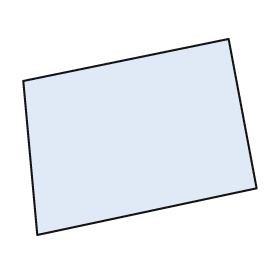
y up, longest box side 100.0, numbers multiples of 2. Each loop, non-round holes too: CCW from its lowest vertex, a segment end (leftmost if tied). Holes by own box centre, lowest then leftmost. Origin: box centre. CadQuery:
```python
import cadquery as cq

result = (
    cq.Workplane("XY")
    .moveTo(-44.0, -42.0)
    .lineTo(50.0, -22.0)
    .lineTo(38.0, 42.0)
    .lineTo(-50.0, 24.0)
    .close()
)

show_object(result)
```